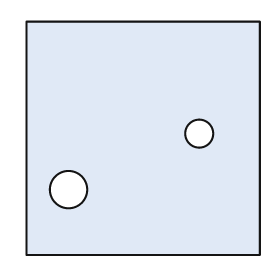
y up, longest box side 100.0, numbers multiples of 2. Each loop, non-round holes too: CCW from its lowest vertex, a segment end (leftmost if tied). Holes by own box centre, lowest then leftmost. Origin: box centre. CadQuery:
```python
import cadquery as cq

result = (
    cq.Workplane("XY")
    .moveTo(-50.0, -50.0)
    .lineTo(50.0, -50.0)
    .lineTo(50.0, 50.0)
    .lineTo(-50.0, 50.0)
    .close()
    .moveTo(-32.0, -22.0)
    .circle(8.0)
    .moveTo(24.0, 2.0)
    .circle(6.0)
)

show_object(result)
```